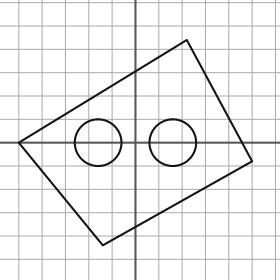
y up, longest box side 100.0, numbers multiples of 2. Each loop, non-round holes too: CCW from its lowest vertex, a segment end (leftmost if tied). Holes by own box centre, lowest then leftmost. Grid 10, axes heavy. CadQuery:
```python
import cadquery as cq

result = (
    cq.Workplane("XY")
    .moveTo(-14.0, -44.0)
    .lineTo(50.0, -8.0)
    .lineTo(22.0, 44.0)
    .lineTo(-50.0, 0.0)
    .close()
    .moveTo(-16.0, 0.0)
    .circle(10.0)
    .moveTo(16.0, 0.0)
    .circle(10.0)
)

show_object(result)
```